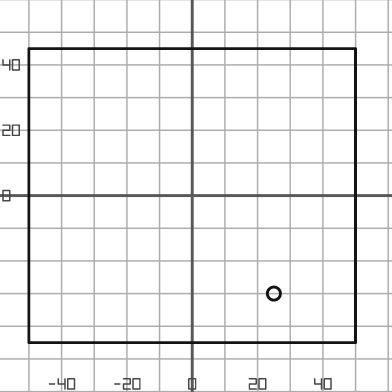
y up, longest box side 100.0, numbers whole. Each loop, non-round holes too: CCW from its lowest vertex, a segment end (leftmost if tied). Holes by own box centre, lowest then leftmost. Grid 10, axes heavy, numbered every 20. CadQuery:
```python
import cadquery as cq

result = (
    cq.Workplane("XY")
    .moveTo(-50.0, -45.0)
    .lineTo(50.0, -45.0)
    .lineTo(50.0, 45.0)
    .lineTo(-50.0, 45.0)
    .close()
    .moveTo(25.0, -30.0)
    .circle(2.0)
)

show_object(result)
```